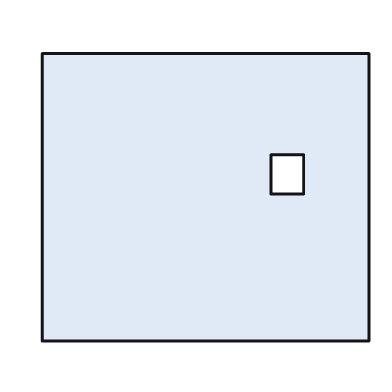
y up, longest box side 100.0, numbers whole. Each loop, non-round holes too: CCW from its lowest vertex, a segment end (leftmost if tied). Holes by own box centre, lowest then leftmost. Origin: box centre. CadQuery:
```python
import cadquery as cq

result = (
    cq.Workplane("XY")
    .moveTo(-50.0, -44.0)
    .lineTo(50.0, -44.0)
    .lineTo(50.0, 44.0)
    .lineTo(-50.0, 44.0)
    .close()
    .moveTo(20.0, 1.0)
    .lineTo(30.0, 1.0)
    .lineTo(30.0, 13.0)
    .lineTo(20.0, 13.0)
    .close()
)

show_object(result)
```